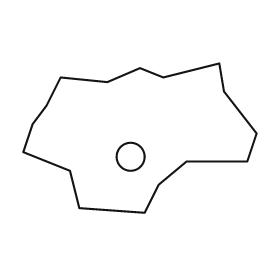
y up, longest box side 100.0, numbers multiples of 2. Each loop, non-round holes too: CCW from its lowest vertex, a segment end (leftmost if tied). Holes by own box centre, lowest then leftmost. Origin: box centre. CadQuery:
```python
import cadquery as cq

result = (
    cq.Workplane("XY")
    .moveTo(2.0, -32.0)
    .lineTo(8.0, -20.0)
    .lineTo(20.0, -10.0)
    .lineTo(46.0, -10.0)
    .lineTo(50.0, 2.0)
    .lineTo(36.0, 20.0)
    .lineTo(34.0, 32.0)
    .lineTo(10.0, 26.0)
    .lineTo(0.0, 30.0)
    .lineTo(-14.0, 24.0)
    .lineTo(-34.0, 26.0)
    .lineTo(-40.0, 14.0)
    .lineTo(-46.0, 6.0)
    .lineTo(-50.0, -6.0)
    .lineTo(-30.0, -14.0)
    .lineTo(-26.0, -30.0)
    .close()
    .moveTo(-4.0, -8.0)
    .circle(6.0)
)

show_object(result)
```